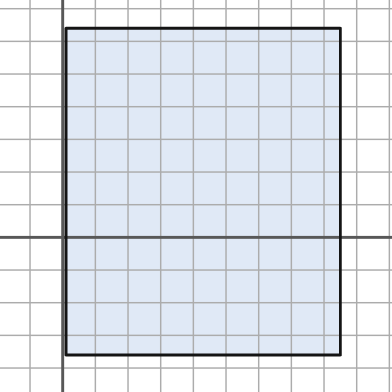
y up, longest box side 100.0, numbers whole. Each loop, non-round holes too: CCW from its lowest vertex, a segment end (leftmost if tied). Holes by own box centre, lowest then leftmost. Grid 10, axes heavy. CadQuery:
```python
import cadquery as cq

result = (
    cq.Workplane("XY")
    .moveTo(1.0, -36.0)
    .lineTo(85.0, -36.0)
    .lineTo(85.0, 64.0)
    .lineTo(1.0, 64.0)
    .close()
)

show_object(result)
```